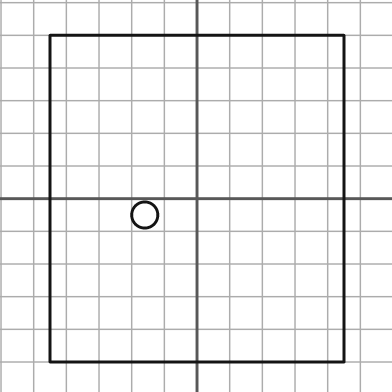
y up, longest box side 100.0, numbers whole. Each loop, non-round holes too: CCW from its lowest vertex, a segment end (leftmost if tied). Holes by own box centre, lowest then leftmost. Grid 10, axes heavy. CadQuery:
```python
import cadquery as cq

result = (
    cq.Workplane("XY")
    .moveTo(-45.0, -50.0)
    .lineTo(45.0, -50.0)
    .lineTo(45.0, 50.0)
    .lineTo(-45.0, 50.0)
    .close()
    .moveTo(-16.0, -5.0)
    .circle(4.0)
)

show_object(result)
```